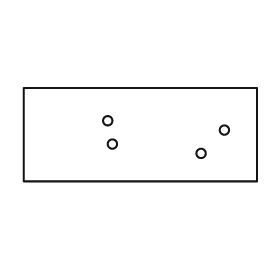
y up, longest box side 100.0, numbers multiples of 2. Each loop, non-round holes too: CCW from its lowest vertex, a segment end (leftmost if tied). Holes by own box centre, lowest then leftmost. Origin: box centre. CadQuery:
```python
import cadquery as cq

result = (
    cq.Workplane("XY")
    .moveTo(-50.0, -20.0)
    .lineTo(50.0, -20.0)
    .lineTo(50.0, 20.0)
    .lineTo(-50.0, 20.0)
    .close()
    .moveTo(26.0, -8.0)
    .circle(2.0)
    .moveTo(-12.0, -4.0)
    .circle(2.0)
    .moveTo(36.0, 2.0)
    .circle(2.0)
    .moveTo(-14.0, 6.0)
    .circle(2.0)
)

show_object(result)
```